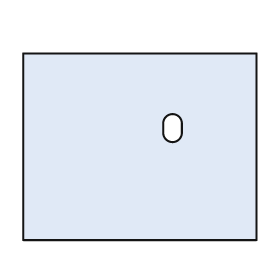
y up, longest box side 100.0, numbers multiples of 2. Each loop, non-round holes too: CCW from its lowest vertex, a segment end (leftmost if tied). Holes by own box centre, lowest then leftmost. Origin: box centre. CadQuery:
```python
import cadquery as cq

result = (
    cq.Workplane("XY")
    .moveTo(-50.0, -40.0)
    .lineTo(50.0, -40.0)
    .lineTo(50.0, 40.0)
    .lineTo(-50.0, 40.0)
    .close()
    .moveTo(10.0, 6.0)
    .threePointArc((14.0, 2.0), (18.0, 6.0))
    .lineTo(18.0, 10.0)
    .threePointArc((14.0, 14.0), (10.0, 10.0))
    .close()
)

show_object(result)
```